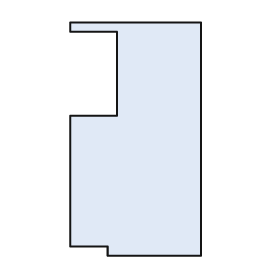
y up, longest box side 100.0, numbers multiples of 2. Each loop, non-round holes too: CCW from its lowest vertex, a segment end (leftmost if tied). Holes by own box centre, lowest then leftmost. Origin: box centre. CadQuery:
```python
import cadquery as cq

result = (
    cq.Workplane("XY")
    .moveTo(-12.0, -50.0)
    .lineTo(28.0, -50.0)
    .lineTo(28.0, 50.0)
    .lineTo(-28.0, 50.0)
    .lineTo(-28.0, 46.0)
    .lineTo(-8.0, 46.0)
    .lineTo(-8.0, 10.0)
    .lineTo(-28.0, 10.0)
    .lineTo(-28.0, -46.0)
    .lineTo(-12.0, -46.0)
    .close()
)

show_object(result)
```